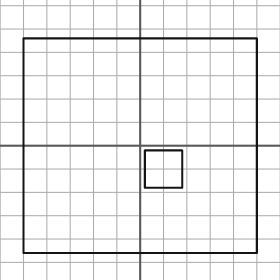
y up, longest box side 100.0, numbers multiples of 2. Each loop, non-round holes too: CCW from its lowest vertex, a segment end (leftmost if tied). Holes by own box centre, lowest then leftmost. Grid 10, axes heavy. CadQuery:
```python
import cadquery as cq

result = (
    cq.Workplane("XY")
    .moveTo(-50.0, -46.0)
    .lineTo(50.0, -46.0)
    .lineTo(50.0, 46.0)
    .lineTo(-50.0, 46.0)
    .close()
    .moveTo(2.0, -18.0)
    .lineTo(18.0, -18.0)
    .lineTo(18.0, -2.0)
    .lineTo(2.0, -2.0)
    .close()
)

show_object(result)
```